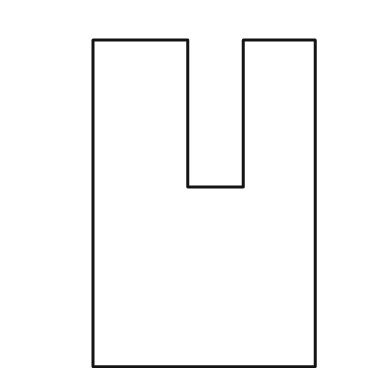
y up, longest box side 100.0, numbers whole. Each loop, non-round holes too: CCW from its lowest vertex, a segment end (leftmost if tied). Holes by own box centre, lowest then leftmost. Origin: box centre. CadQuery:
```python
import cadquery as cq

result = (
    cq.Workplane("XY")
    .moveTo(-34.0, -50.0)
    .lineTo(34.0, -50.0)
    .lineTo(34.0, 50.0)
    .lineTo(12.0, 50.0)
    .lineTo(12.0, 5.0)
    .lineTo(-5.0, 5.0)
    .lineTo(-5.0, 50.0)
    .lineTo(-34.0, 50.0)
    .close()
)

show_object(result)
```